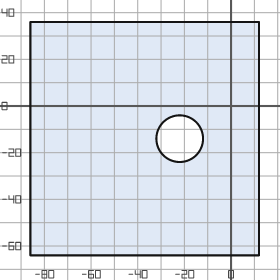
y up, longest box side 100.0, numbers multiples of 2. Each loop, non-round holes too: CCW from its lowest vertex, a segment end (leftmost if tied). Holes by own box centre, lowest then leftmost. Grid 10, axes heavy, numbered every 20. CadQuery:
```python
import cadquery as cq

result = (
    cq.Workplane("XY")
    .moveTo(-86.0, -64.0)
    .lineTo(12.0, -64.0)
    .lineTo(12.0, 36.0)
    .lineTo(-86.0, 36.0)
    .close()
    .moveTo(-22.0, -14.0)
    .circle(10.0)
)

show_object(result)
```